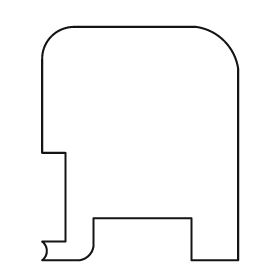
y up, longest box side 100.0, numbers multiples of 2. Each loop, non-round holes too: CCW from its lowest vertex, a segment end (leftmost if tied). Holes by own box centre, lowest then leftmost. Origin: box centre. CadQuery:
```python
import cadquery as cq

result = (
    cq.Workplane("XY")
    .moveTo(-42.0, -50.0)
    .lineTo(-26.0, -50.0)
    .threePointArc((-22.0, -48.0), (-20.0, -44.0))
    .lineTo(-20.0, -32.0)
    .lineTo(22.0, -32.0)
    .lineTo(22.0, -50.0)
    .lineTo(42.0, -50.0)
    .lineTo(42.0, 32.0)
    .threePointArc((36.0, 44.0), (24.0, 50.0))
    .lineTo(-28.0, 50.0)
    .threePointArc((-38.0, 46.0), (-42.0, 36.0))
    .lineTo(-42.0, -4.0)
    .lineTo(-32.0, -4.0)
    .lineTo(-32.0, -42.0)
    .lineTo(-42.0, -42.0)
    .threePointArc((-40.0, -46.0), (-42.0, -50.0))
    .close()
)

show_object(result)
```